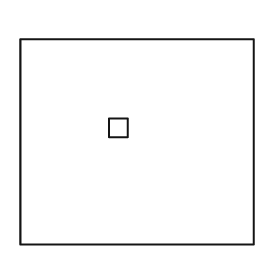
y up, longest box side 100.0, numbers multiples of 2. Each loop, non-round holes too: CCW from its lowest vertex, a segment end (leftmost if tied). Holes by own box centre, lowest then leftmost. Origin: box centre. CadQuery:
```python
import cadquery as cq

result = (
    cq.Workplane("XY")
    .moveTo(-50.0, -44.0)
    .lineTo(50.0, -44.0)
    .lineTo(50.0, 44.0)
    .lineTo(-50.0, 44.0)
    .close()
    .moveTo(-12.0, 2.0)
    .lineTo(-4.0, 2.0)
    .lineTo(-4.0, 10.0)
    .lineTo(-12.0, 10.0)
    .close()
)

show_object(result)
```